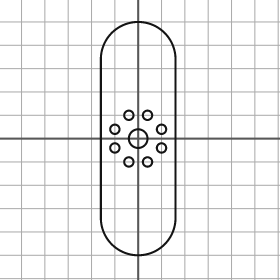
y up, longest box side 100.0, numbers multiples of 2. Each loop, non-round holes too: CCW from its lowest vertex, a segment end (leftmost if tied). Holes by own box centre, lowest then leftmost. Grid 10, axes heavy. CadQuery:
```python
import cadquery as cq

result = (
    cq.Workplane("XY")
    .moveTo(-16.0, -34.0)
    .threePointArc((0.0, -50.0), (16.0, -34.0))
    .lineTo(16.0, 34.0)
    .threePointArc((0.0, 50.0), (-16.0, 34.0))
    .close()
    .moveTo(-4.0, -10.0)
    .circle(2.0)
    .moveTo(4.0, -10.0)
    .circle(2.0)
    .moveTo(-10.0, -4.0)
    .circle(2.0)
    .moveTo(10.0, -4.0)
    .circle(2.0)
    .moveTo(0.0, 0.0)
    .circle(4.0)
    .moveTo(-10.0, 4.0)
    .circle(2.0)
    .moveTo(10.0, 4.0)
    .circle(2.0)
    .moveTo(-4.0, 10.0)
    .circle(2.0)
    .moveTo(4.0, 10.0)
    .circle(2.0)
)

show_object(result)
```